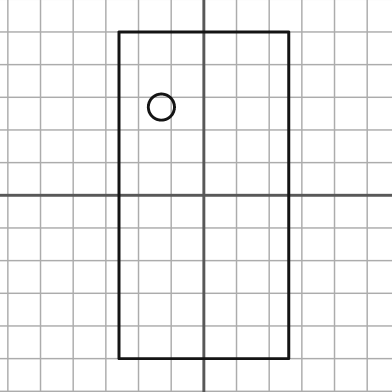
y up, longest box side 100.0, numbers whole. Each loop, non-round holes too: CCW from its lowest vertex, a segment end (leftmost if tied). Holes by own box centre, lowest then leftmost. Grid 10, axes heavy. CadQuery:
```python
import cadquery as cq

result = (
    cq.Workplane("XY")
    .moveTo(-26.0, -50.0)
    .lineTo(26.0, -50.0)
    .lineTo(26.0, 50.0)
    .lineTo(-26.0, 50.0)
    .close()
    .moveTo(-13.0, 27.0)
    .circle(4.0)
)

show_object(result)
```